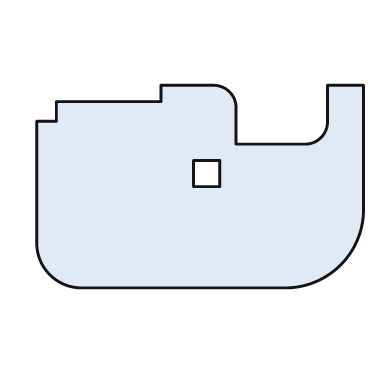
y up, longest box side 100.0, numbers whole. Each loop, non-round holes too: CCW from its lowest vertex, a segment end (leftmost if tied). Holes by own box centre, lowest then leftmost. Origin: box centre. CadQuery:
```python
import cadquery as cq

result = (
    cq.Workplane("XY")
    .moveTo(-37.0, -31.0)
    .lineTo(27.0, -31.0)
    .threePointArc((43.0, -24.0), (50.0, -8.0))
    .lineTo(50.0, 31.0)
    .lineTo(39.0, 31.0)
    .lineTo(39.0, 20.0)
    .threePointArc((37.0, 15.0), (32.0, 13.0))
    .lineTo(11.0, 13.0)
    .lineTo(11.0, 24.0)
    .threePointArc((9.0, 29.0), (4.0, 31.0))
    .lineTo(-12.0, 31.0)
    .lineTo(-12.0, 26.0)
    .lineTo(-44.0, 26.0)
    .lineTo(-44.0, 20.0)
    .lineTo(-50.0, 20.0)
    .lineTo(-50.0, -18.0)
    .threePointArc((-46.0, -27.0), (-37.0, -31.0))
    .close()
    .moveTo(-2.0, 0.0)
    .lineTo(6.0, 0.0)
    .lineTo(6.0, 8.0)
    .lineTo(-2.0, 8.0)
    .close()
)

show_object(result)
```